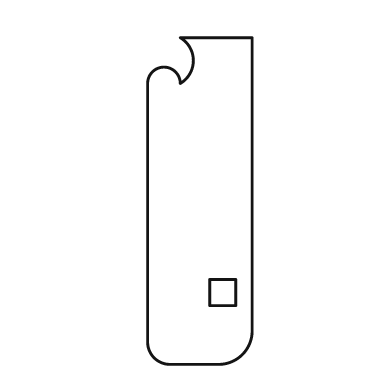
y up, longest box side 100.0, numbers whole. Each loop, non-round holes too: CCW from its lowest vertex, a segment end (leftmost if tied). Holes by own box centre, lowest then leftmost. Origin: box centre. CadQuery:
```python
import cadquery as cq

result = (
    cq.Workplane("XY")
    .moveTo(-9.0, -50.0)
    .lineTo(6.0, -50.0)
    .threePointArc((13.0, -47.0), (16.0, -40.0))
    .lineTo(16.0, 50.0)
    .lineTo(-6.0, 50.0)
    .threePointArc((-2.0, 43.0), (-6.0, 36.0))
    .threePointArc((-11.0, 41.0), (-16.0, 36.0))
    .lineTo(-16.0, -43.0)
    .threePointArc((-14.0, -48.0), (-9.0, -50.0))
    .close()
    .moveTo(3.0, -32.0)
    .lineTo(11.0, -32.0)
    .lineTo(11.0, -24.0)
    .lineTo(3.0, -24.0)
    .close()
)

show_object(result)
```